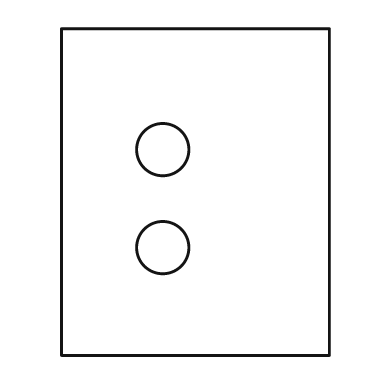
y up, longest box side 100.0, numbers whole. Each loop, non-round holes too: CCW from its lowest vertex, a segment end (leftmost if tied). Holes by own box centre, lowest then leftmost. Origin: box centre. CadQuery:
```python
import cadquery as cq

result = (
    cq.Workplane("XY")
    .moveTo(-41.0, -50.0)
    .lineTo(41.0, -50.0)
    .lineTo(41.0, 50.0)
    .lineTo(-41.0, 50.0)
    .close()
    .moveTo(-10.0, -17.0)
    .circle(8.0)
    .moveTo(-10.0, 13.0)
    .circle(8.0)
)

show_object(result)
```